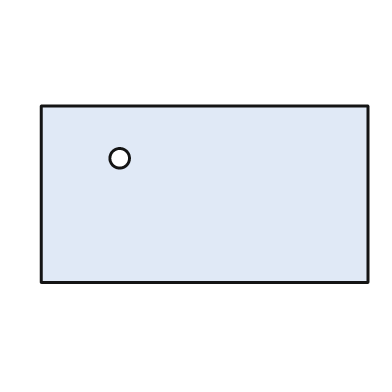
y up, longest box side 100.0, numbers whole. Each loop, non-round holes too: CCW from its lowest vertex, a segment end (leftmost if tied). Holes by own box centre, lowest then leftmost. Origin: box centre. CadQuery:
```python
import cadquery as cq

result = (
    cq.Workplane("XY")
    .moveTo(-50.0, -27.0)
    .lineTo(50.0, -27.0)
    .lineTo(50.0, 27.0)
    .lineTo(-50.0, 27.0)
    .close()
    .moveTo(-26.0, 11.0)
    .circle(3.0)
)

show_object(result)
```